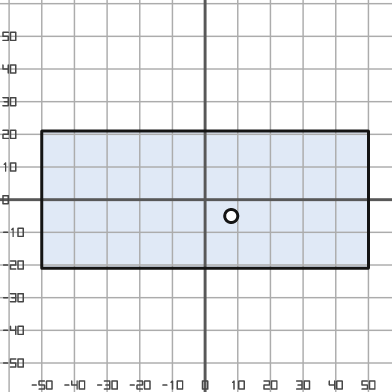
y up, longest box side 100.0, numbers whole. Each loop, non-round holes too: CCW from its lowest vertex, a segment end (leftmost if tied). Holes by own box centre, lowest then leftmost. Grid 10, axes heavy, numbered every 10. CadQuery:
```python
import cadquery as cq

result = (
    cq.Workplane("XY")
    .moveTo(-50.0, -21.0)
    .lineTo(50.0, -21.0)
    .lineTo(50.0, 21.0)
    .lineTo(-50.0, 21.0)
    .close()
    .moveTo(8.0, -5.0)
    .circle(2.0)
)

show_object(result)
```